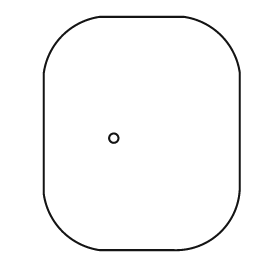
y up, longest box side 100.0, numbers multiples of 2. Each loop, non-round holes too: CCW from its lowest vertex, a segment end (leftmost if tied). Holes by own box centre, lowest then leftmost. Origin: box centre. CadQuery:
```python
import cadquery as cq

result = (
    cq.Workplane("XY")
    .moveTo(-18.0, -50.0)
    .lineTo(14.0, -50.0)
    .threePointArc((34.0, -42.0), (42.0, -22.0))
    .lineTo(42.0, 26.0)
    .threePointArc((34.0, 42.0), (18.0, 50.0))
    .lineTo(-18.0, 50.0)
    .threePointArc((-34.0, 42.0), (-42.0, 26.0))
    .lineTo(-42.0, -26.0)
    .threePointArc((-34.0, -42.0), (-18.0, -50.0))
    .close()
    .moveTo(-12.0, -2.0)
    .circle(2.0)
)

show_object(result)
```